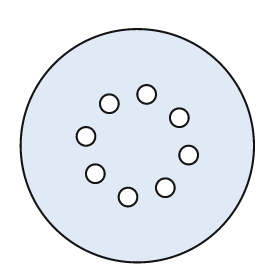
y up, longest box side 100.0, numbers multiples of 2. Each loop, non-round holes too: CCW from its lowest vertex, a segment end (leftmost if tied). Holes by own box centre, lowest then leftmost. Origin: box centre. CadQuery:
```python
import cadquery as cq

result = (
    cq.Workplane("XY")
    .moveTo(0.0, 0.0)
    .circle(50.0)
    .moveTo(-4.0, -22.0)
    .circle(4.0)
    .moveTo(12.0, -18.0)
    .circle(4.0)
    .moveTo(-18.0, -12.0)
    .circle(4.0)
    .moveTo(22.0, -4.0)
    .circle(4.0)
    .moveTo(-22.0, 4.0)
    .circle(4.0)
    .moveTo(18.0, 12.0)
    .circle(4.0)
    .moveTo(-12.0, 18.0)
    .circle(4.0)
    .moveTo(4.0, 22.0)
    .circle(4.0)
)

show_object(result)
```